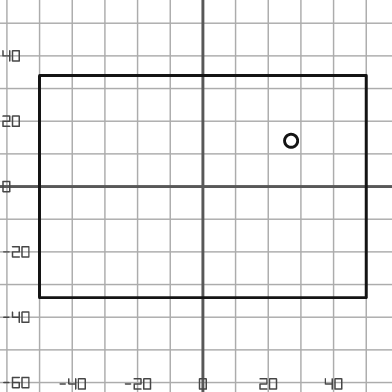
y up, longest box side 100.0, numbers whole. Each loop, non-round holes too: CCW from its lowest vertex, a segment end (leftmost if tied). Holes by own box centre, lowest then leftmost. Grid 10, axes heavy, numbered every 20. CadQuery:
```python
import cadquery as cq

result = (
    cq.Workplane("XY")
    .moveTo(-50.0, -34.0)
    .lineTo(50.0, -34.0)
    .lineTo(50.0, 34.0)
    .lineTo(-50.0, 34.0)
    .close()
    .moveTo(27.0, 14.0)
    .circle(2.0)
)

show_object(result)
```